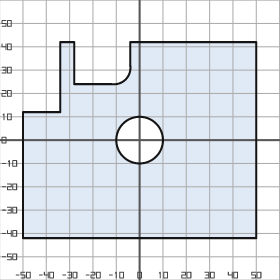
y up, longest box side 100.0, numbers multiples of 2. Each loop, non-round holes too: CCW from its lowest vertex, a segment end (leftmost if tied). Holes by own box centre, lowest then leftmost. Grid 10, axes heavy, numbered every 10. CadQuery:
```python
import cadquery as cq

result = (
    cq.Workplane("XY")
    .moveTo(-50.0, -42.0)
    .lineTo(50.0, -42.0)
    .lineTo(50.0, 42.0)
    .lineTo(-4.0, 42.0)
    .lineTo(-4.0, 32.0)
    .threePointArc((-6.0, 26.0), (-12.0, 24.0))
    .lineTo(-28.0, 24.0)
    .lineTo(-28.0, 42.0)
    .lineTo(-34.0, 42.0)
    .lineTo(-34.0, 12.0)
    .lineTo(-50.0, 12.0)
    .close()
    .moveTo(0.0, 0.0)
    .circle(10.0)
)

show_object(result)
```